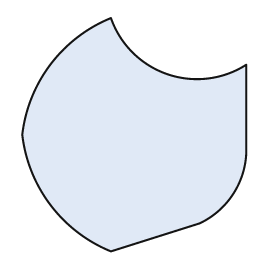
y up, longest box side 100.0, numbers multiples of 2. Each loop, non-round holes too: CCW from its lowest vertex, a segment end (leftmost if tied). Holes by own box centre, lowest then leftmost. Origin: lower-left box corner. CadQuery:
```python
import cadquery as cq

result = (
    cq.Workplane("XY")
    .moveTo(38.0, 0.0)
    .lineTo(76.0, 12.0)
    .threePointArc((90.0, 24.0), (96.0, 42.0))
    .lineTo(96.0, 80.0)
    .threePointArc((62.0, 76.0), (38.0, 100.0))
    .threePointArc((12.0, 80.0), (0.0, 50.0))
    .threePointArc((12.0, 20.0), (38.0, 0.0))
    .close()
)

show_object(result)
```